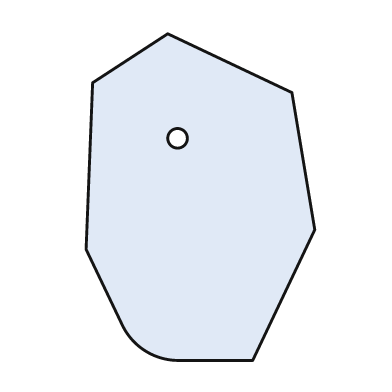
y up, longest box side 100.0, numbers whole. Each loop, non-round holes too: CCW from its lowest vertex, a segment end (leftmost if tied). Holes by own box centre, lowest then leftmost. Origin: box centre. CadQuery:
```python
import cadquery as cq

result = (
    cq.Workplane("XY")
    .moveTo(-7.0, -50.0)
    .lineTo(16.0, -50.0)
    .lineTo(35.0, -10.0)
    .lineTo(28.0, 32.0)
    .lineTo(-10.0, 50.0)
    .lineTo(-33.0, 35.0)
    .lineTo(-35.0, -16.0)
    .lineTo(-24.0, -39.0)
    .threePointArc((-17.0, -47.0), (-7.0, -50.0))
    .close()
    .moveTo(-7.0, 18.0)
    .circle(3.0)
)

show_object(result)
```